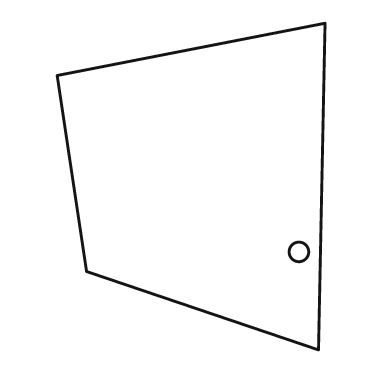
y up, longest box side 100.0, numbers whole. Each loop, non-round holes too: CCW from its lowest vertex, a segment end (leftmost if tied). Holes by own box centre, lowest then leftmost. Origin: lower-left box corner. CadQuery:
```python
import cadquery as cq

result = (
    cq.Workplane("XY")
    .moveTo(80.0, 0.0)
    .lineTo(82.0, 100.0)
    .lineTo(0.0, 84.0)
    .lineTo(9.0, 24.0)
    .close()
    .moveTo(74.0, 30.0)
    .circle(3.0)
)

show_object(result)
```